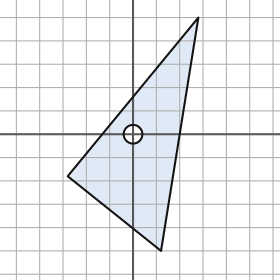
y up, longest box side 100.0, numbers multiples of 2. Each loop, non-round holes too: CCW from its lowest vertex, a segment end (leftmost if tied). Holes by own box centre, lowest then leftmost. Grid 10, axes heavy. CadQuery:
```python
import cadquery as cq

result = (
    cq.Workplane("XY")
    .moveTo(12.0, -50.0)
    .lineTo(28.0, 50.0)
    .lineTo(-28.0, -18.0)
    .close()
    .moveTo(0.0, 0.0)
    .circle(4.0)
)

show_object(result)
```